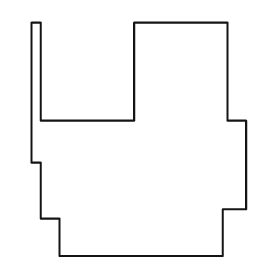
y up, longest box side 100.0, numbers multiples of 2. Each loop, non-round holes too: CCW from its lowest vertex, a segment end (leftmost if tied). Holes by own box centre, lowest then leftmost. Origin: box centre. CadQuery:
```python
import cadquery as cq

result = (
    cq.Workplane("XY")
    .moveTo(-34.0, -50.0)
    .lineTo(36.0, -50.0)
    .lineTo(36.0, -30.0)
    .lineTo(46.0, -30.0)
    .lineTo(46.0, 8.0)
    .lineTo(38.0, 8.0)
    .lineTo(38.0, 50.0)
    .lineTo(-2.0, 50.0)
    .lineTo(-2.0, 8.0)
    .lineTo(-42.0, 8.0)
    .lineTo(-42.0, 50.0)
    .lineTo(-46.0, 50.0)
    .lineTo(-46.0, -10.0)
    .lineTo(-42.0, -10.0)
    .lineTo(-42.0, -34.0)
    .lineTo(-34.0, -34.0)
    .close()
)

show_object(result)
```